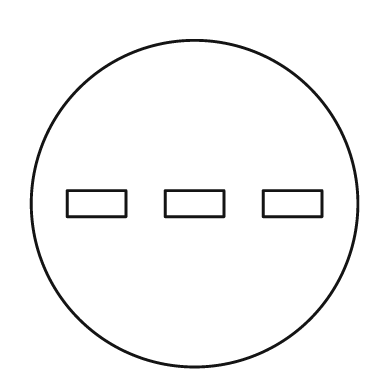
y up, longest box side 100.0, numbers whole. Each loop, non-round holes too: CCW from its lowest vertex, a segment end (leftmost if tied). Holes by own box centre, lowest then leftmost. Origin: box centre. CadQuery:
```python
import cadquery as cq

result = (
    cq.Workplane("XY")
    .moveTo(0.0, 0.0)
    .circle(50.0)
    .moveTo(-39.0, -4.0)
    .lineTo(-21.0, -4.0)
    .lineTo(-21.0, 4.0)
    .lineTo(-39.0, 4.0)
    .close()
    .moveTo(-9.0, -4.0)
    .lineTo(9.0, -4.0)
    .lineTo(9.0, 4.0)
    .lineTo(-9.0, 4.0)
    .close()
    .moveTo(21.0, -4.0)
    .lineTo(39.0, -4.0)
    .lineTo(39.0, 4.0)
    .lineTo(21.0, 4.0)
    .close()
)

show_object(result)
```